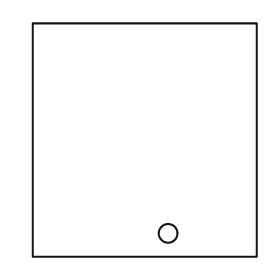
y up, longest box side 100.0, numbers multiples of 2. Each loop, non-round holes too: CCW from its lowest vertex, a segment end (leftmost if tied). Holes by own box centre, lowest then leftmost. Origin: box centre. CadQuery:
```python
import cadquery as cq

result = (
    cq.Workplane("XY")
    .moveTo(-48.0, -50.0)
    .lineTo(48.0, -50.0)
    .lineTo(48.0, 50.0)
    .lineTo(-48.0, 50.0)
    .close()
    .moveTo(10.0, -40.0)
    .circle(4.0)
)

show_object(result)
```